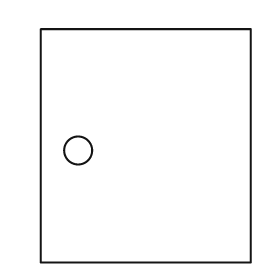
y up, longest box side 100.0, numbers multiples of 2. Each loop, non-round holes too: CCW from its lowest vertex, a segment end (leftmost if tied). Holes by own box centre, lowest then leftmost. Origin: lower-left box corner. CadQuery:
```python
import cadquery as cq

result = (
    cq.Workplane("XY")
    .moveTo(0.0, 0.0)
    .lineTo(90.0, 0.0)
    .lineTo(90.0, 100.0)
    .lineTo(0.0, 100.0)
    .close()
    .moveTo(16.0, 48.0)
    .circle(6.0)
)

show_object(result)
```